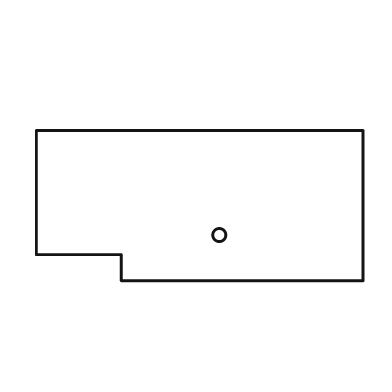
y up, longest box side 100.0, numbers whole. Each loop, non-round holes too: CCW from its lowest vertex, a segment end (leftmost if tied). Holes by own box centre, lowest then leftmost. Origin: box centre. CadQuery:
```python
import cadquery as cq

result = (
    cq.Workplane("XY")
    .moveTo(-24.0, -23.0)
    .lineTo(50.0, -23.0)
    .lineTo(50.0, 23.0)
    .lineTo(-50.0, 23.0)
    .lineTo(-50.0, -15.0)
    .lineTo(-24.0, -15.0)
    .close()
    .moveTo(6.0, -9.0)
    .circle(2.0)
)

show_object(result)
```